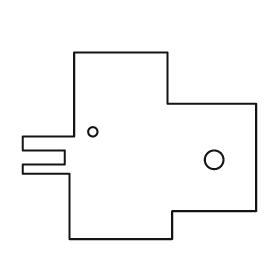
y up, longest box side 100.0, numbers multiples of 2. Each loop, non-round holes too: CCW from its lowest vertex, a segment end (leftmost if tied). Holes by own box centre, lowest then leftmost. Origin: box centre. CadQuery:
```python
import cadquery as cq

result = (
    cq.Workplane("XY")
    .moveTo(-30.0, -40.0)
    .lineTo(14.0, -40.0)
    .lineTo(14.0, -28.0)
    .lineTo(50.0, -28.0)
    .lineTo(50.0, 18.0)
    .lineTo(12.0, 18.0)
    .lineTo(12.0, 40.0)
    .lineTo(-28.0, 40.0)
    .lineTo(-28.0, 4.0)
    .lineTo(-50.0, 4.0)
    .lineTo(-50.0, -2.0)
    .lineTo(-32.0, -2.0)
    .lineTo(-32.0, -8.0)
    .lineTo(-50.0, -8.0)
    .lineTo(-50.0, -12.0)
    .lineTo(-30.0, -12.0)
    .close()
    .moveTo(32.0, -6.0)
    .circle(4.0)
    .moveTo(-20.0, 6.0)
    .circle(2.0)
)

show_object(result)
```